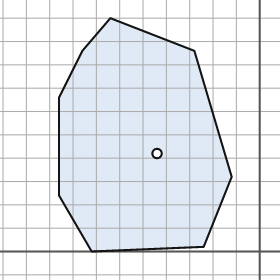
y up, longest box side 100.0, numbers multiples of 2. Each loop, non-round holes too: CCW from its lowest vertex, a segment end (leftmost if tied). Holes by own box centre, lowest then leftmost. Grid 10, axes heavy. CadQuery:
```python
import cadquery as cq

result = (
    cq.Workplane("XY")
    .moveTo(-72.0, 0.0)
    .lineTo(-24.0, 2.0)
    .lineTo(-12.0, 32.0)
    .lineTo(-28.0, 86.0)
    .lineTo(-64.0, 100.0)
    .lineTo(-76.0, 86.0)
    .lineTo(-86.0, 66.0)
    .lineTo(-86.0, 24.0)
    .close()
    .moveTo(-44.0, 42.0)
    .circle(2.0)
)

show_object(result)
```